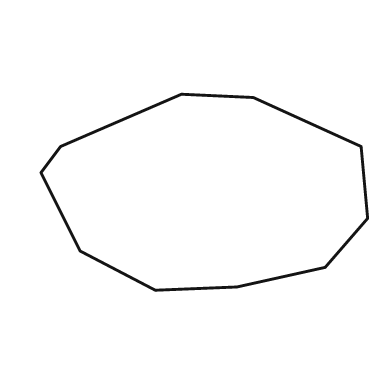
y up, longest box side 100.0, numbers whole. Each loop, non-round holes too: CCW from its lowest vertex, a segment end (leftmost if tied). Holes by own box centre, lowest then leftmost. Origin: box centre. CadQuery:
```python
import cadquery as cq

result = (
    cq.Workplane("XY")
    .moveTo(-15.0, -30.0)
    .lineTo(10.0, -29.0)
    .lineTo(37.0, -23.0)
    .lineTo(50.0, -8.0)
    .lineTo(48.0, 14.0)
    .lineTo(15.0, 29.0)
    .lineTo(-7.0, 30.0)
    .lineTo(-44.0, 14.0)
    .lineTo(-50.0, 6.0)
    .lineTo(-38.0, -18.0)
    .close()
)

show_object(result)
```